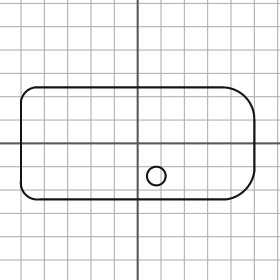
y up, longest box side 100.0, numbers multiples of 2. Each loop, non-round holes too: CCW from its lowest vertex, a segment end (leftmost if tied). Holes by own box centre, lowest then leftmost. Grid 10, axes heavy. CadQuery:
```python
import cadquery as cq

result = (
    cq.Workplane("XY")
    .moveTo(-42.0, -24.0)
    .lineTo(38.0, -24.0)
    .threePointArc((46.0, -20.0), (50.0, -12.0))
    .lineTo(50.0, 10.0)
    .threePointArc((46.0, 20.0), (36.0, 24.0))
    .lineTo(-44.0, 24.0)
    .threePointArc((-48.0, 22.0), (-50.0, 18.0))
    .lineTo(-50.0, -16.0)
    .threePointArc((-48.0, -22.0), (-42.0, -24.0))
    .close()
    .moveTo(8.0, -14.0)
    .circle(4.0)
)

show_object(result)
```